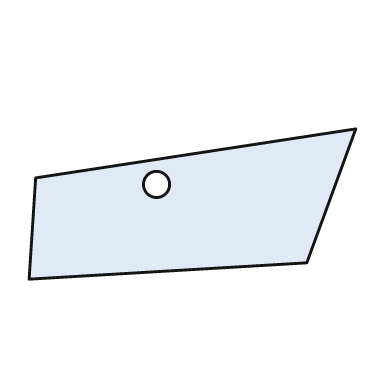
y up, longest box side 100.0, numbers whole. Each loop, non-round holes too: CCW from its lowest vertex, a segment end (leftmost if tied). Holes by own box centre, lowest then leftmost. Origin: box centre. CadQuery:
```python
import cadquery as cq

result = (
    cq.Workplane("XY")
    .moveTo(-50.0, -23.0)
    .lineTo(35.0, -18.0)
    .lineTo(50.0, 23.0)
    .lineTo(-48.0, 8.0)
    .close()
    .moveTo(-11.0, 6.0)
    .circle(4.0)
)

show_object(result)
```